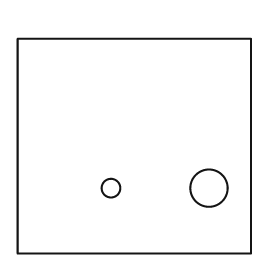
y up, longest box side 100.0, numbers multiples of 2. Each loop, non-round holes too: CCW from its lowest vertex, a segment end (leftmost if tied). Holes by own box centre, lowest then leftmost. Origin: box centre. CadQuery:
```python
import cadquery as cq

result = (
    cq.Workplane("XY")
    .moveTo(-50.0, -46.0)
    .lineTo(50.0, -46.0)
    .lineTo(50.0, 46.0)
    .lineTo(-50.0, 46.0)
    .close()
    .moveTo(-10.0, -18.0)
    .circle(4.0)
    .moveTo(32.0, -18.0)
    .circle(8.0)
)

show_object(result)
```